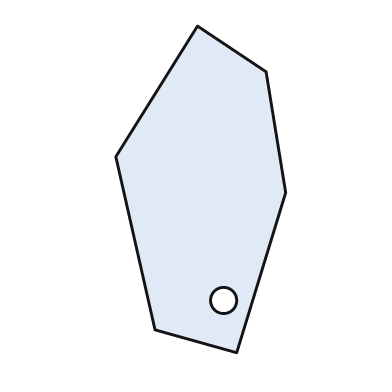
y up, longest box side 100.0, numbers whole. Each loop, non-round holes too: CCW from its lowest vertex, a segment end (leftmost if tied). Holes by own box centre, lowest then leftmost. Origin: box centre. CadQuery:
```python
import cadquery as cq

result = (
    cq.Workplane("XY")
    .moveTo(11.0, -50.0)
    .lineTo(26.0, -1.0)
    .lineTo(20.0, 36.0)
    .lineTo(-1.0, 50.0)
    .lineTo(-26.0, 10.0)
    .lineTo(-14.0, -43.0)
    .close()
    .moveTo(7.0, -34.0)
    .circle(4.0)
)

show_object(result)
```